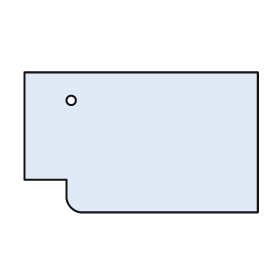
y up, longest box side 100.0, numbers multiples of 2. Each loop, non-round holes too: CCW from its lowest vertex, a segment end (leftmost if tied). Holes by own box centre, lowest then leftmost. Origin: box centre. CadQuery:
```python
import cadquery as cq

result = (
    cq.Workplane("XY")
    .moveTo(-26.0, -30.0)
    .lineTo(50.0, -30.0)
    .lineTo(50.0, 30.0)
    .lineTo(-50.0, 30.0)
    .lineTo(-50.0, -16.0)
    .lineTo(-32.0, -16.0)
    .lineTo(-32.0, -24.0)
    .threePointArc((-30.0, -28.0), (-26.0, -30.0))
    .close()
    .moveTo(-30.0, 18.0)
    .circle(2.0)
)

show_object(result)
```